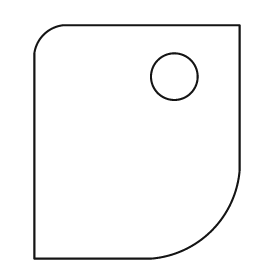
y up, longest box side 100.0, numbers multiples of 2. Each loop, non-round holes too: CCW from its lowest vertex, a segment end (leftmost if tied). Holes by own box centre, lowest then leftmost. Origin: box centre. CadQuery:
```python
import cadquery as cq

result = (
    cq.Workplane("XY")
    .moveTo(-44.0, -50.0)
    .lineTo(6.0, -50.0)
    .threePointArc((32.0, -38.0), (44.0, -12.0))
    .lineTo(44.0, 50.0)
    .lineTo(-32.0, 50.0)
    .threePointArc((-40.0, 46.0), (-44.0, 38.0))
    .close()
    .moveTo(16.0, 28.0)
    .circle(10.0)
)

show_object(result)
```